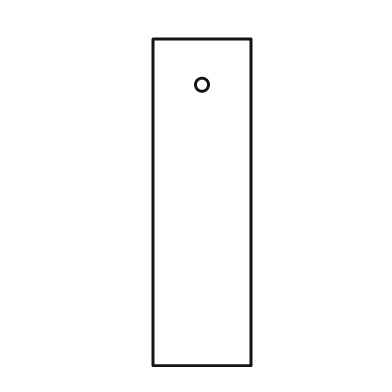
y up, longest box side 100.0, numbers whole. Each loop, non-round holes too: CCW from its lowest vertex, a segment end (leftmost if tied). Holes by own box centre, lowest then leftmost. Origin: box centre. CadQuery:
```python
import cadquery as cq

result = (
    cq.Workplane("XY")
    .moveTo(-15.0, -50.0)
    .lineTo(15.0, -50.0)
    .lineTo(15.0, 50.0)
    .lineTo(-15.0, 50.0)
    .close()
    .moveTo(0.0, 36.0)
    .circle(2.0)
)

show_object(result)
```